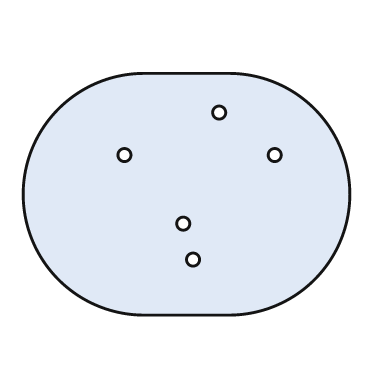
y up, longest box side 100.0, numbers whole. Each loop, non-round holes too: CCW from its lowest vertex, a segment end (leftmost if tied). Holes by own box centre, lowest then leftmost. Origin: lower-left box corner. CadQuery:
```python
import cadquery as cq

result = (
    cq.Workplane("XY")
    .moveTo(37.0, 0.0)
    .lineTo(63.0, 0.0)
    .threePointArc((100.0, 37.0), (63.0, 74.0))
    .lineTo(37.0, 74.0)
    .threePointArc((0.0, 37.0), (37.0, 0.0))
    .close()
    .moveTo(52.0, 17.0)
    .circle(2.0)
    .moveTo(49.0, 28.0)
    .circle(2.0)
    .moveTo(31.0, 49.0)
    .circle(2.0)
    .moveTo(77.0, 49.0)
    .circle(2.0)
    .moveTo(60.0, 62.0)
    .circle(2.0)
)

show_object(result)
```